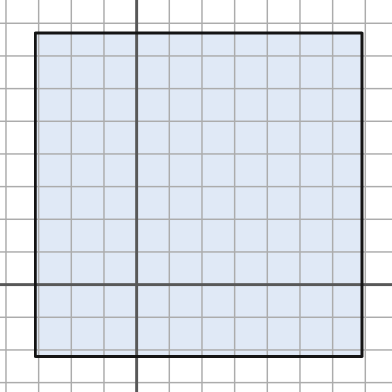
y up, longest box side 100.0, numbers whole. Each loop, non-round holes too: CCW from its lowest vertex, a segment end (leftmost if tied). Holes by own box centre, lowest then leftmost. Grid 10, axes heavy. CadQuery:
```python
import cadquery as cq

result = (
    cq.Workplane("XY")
    .moveTo(-31.0, -22.0)
    .lineTo(69.0, -22.0)
    .lineTo(69.0, 77.0)
    .lineTo(-31.0, 77.0)
    .close()
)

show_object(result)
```